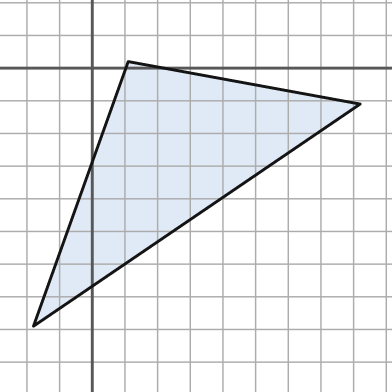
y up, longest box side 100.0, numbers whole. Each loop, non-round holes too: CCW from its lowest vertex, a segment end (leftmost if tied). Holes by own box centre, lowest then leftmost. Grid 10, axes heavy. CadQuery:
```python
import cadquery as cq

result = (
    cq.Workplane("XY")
    .moveTo(-18.0, -79.0)
    .lineTo(82.0, -11.0)
    .lineTo(11.0, 2.0)
    .close()
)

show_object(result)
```